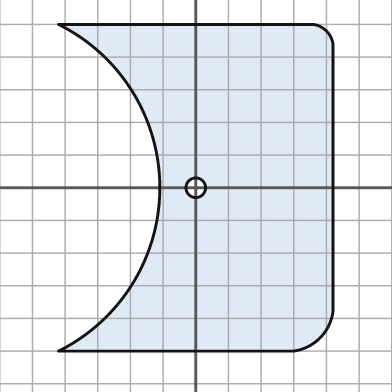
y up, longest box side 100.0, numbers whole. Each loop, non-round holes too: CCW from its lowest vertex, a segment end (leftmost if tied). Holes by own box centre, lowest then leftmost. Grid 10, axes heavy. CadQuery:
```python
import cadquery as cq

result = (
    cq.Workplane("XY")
    .moveTo(-42.0, -50.0)
    .lineTo(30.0, -50.0)
    .threePointArc((38.0, -46.0), (42.0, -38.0))
    .lineTo(42.0, 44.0)
    .threePointArc((40.0, 48.0), (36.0, 50.0))
    .lineTo(-42.0, 50.0)
    .threePointArc((-11.0, 0.0), (-42.0, -50.0))
    .close()
    .moveTo(0.0, 0.0)
    .circle(3.0)
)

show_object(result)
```